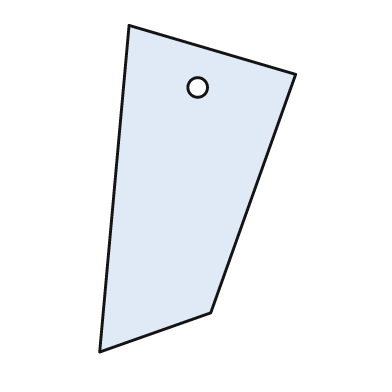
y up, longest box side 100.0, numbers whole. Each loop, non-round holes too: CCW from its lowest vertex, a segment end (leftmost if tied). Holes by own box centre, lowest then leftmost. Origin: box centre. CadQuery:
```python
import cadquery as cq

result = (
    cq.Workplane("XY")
    .moveTo(-30.0, -50.0)
    .lineTo(4.0, -38.0)
    .lineTo(30.0, 35.0)
    .lineTo(-21.0, 50.0)
    .close()
    .moveTo(0.0, 31.0)
    .circle(3.0)
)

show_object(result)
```